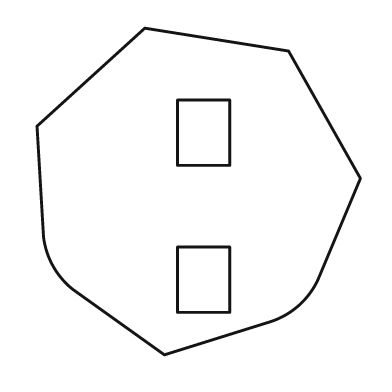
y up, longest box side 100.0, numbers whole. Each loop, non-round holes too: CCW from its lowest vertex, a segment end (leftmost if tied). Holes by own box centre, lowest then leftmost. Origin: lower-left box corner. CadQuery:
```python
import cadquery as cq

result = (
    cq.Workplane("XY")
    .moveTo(39.0, 0.0)
    .lineTo(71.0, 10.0)
    .threePointArc((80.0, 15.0), (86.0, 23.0))
    .lineTo(99.0, 54.0)
    .lineTo(77.0, 93.0)
    .lineTo(33.0, 100.0)
    .lineTo(0.0, 70.0)
    .lineTo(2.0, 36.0)
    .threePointArc((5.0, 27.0), (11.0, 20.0))
    .close()
    .moveTo(43.0, 13.0)
    .lineTo(59.0, 13.0)
    .lineTo(59.0, 33.0)
    .lineTo(43.0, 33.0)
    .close()
    .moveTo(43.0, 58.0)
    .lineTo(59.0, 58.0)
    .lineTo(59.0, 78.0)
    .lineTo(43.0, 78.0)
    .close()
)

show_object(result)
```